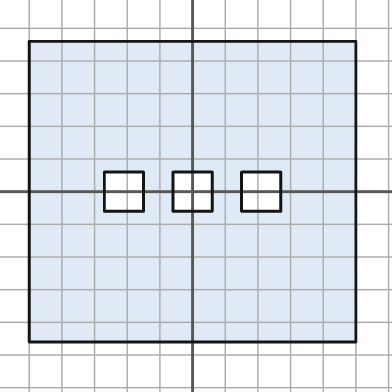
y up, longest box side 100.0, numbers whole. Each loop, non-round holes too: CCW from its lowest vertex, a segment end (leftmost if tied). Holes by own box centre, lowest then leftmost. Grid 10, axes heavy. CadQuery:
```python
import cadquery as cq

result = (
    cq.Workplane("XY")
    .moveTo(-50.0, -46.0)
    .lineTo(50.0, -46.0)
    .lineTo(50.0, 46.0)
    .lineTo(-50.0, 46.0)
    .close()
    .moveTo(-27.0, -6.0)
    .lineTo(-15.0, -6.0)
    .lineTo(-15.0, 6.0)
    .lineTo(-27.0, 6.0)
    .close()
    .moveTo(-6.0, -6.0)
    .lineTo(6.0, -6.0)
    .lineTo(6.0, 6.0)
    .lineTo(-6.0, 6.0)
    .close()
    .moveTo(15.0, -6.0)
    .lineTo(27.0, -6.0)
    .lineTo(27.0, 6.0)
    .lineTo(15.0, 6.0)
    .close()
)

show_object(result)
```